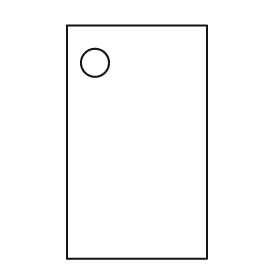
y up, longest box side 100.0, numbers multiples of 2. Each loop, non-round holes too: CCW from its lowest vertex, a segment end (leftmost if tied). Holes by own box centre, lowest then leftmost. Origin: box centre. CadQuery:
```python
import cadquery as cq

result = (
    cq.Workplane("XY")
    .moveTo(-30.0, -50.0)
    .lineTo(30.0, -50.0)
    .lineTo(30.0, 50.0)
    .lineTo(-30.0, 50.0)
    .close()
    .moveTo(-18.0, 34.0)
    .circle(6.0)
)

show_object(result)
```